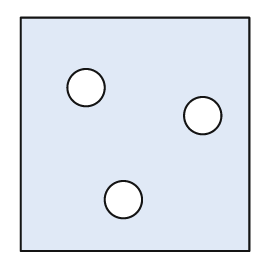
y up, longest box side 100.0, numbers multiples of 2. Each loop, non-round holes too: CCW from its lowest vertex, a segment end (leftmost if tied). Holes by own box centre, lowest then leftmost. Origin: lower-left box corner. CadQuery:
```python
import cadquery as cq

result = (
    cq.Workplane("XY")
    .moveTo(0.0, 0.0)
    .lineTo(98.0, 0.0)
    .lineTo(98.0, 100.0)
    .lineTo(0.0, 100.0)
    .close()
    .moveTo(44.0, 22.0)
    .circle(8.0)
    .moveTo(78.0, 58.0)
    .circle(8.0)
    .moveTo(28.0, 70.0)
    .circle(8.0)
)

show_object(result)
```